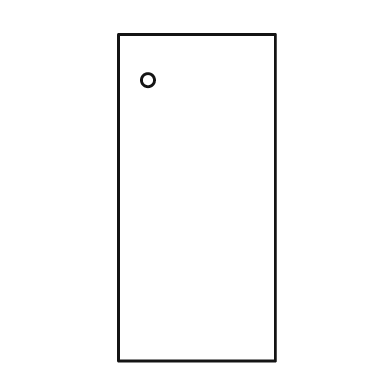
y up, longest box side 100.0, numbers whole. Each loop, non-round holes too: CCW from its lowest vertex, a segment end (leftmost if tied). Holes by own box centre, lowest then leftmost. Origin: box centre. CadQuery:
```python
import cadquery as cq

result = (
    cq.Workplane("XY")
    .moveTo(-24.0, -50.0)
    .lineTo(24.0, -50.0)
    .lineTo(24.0, 50.0)
    .lineTo(-24.0, 50.0)
    .close()
    .moveTo(-15.0, 36.0)
    .circle(2.0)
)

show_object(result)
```